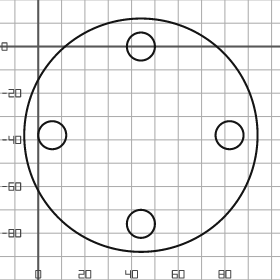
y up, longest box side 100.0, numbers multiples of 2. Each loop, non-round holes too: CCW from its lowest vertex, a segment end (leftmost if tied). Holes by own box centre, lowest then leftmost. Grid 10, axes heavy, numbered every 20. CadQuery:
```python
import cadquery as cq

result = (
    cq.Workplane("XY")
    .moveTo(44.0, -38.0)
    .circle(50.0)
    .moveTo(44.0, -76.0)
    .circle(6.0)
    .moveTo(6.0, -38.0)
    .circle(6.0)
    .moveTo(82.0, -38.0)
    .circle(6.0)
    .moveTo(44.0, 0.0)
    .circle(6.0)
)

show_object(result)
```